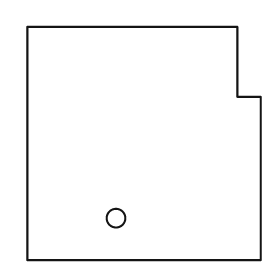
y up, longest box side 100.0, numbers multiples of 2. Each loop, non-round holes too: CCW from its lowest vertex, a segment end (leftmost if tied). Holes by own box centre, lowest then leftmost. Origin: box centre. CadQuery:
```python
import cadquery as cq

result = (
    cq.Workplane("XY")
    .moveTo(-50.0, -50.0)
    .lineTo(50.0, -50.0)
    .lineTo(50.0, 20.0)
    .lineTo(40.0, 20.0)
    .lineTo(40.0, 50.0)
    .lineTo(-50.0, 50.0)
    .close()
    .moveTo(-12.0, -32.0)
    .circle(4.0)
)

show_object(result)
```